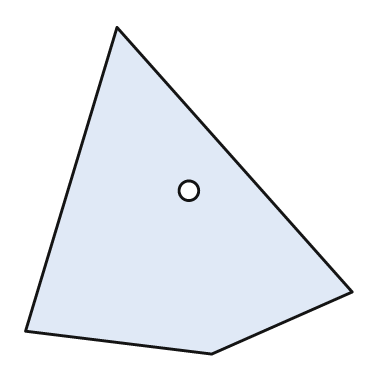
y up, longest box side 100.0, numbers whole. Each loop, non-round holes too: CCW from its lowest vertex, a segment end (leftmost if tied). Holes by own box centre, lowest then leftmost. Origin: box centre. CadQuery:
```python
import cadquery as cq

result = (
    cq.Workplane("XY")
    .moveTo(7.0, -50.0)
    .lineTo(50.0, -31.0)
    .lineTo(-22.0, 50.0)
    .lineTo(-50.0, -43.0)
    .close()
    .moveTo(0.0, 0.0)
    .circle(3.0)
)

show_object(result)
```